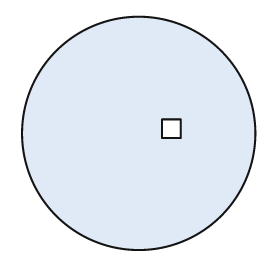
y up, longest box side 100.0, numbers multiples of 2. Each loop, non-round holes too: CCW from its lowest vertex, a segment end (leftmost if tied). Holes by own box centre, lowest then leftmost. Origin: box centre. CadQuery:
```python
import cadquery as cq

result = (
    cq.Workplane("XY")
    .moveTo(0.0, 0.0)
    .circle(50.0)
    .moveTo(10.0, -2.0)
    .lineTo(18.0, -2.0)
    .lineTo(18.0, 6.0)
    .lineTo(10.0, 6.0)
    .close()
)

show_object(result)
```